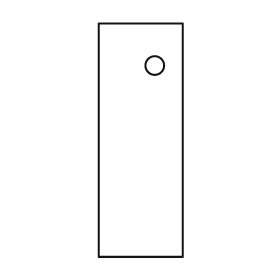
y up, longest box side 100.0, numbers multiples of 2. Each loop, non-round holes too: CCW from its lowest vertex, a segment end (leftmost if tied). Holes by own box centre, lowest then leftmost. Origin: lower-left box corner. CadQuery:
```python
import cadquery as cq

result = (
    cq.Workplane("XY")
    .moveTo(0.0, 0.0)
    .lineTo(36.0, 0.0)
    .lineTo(36.0, 100.0)
    .lineTo(0.0, 100.0)
    .close()
    .moveTo(24.0, 82.0)
    .circle(4.0)
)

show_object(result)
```